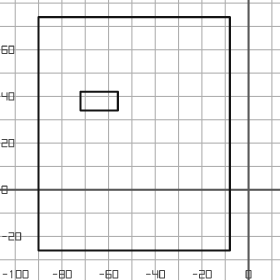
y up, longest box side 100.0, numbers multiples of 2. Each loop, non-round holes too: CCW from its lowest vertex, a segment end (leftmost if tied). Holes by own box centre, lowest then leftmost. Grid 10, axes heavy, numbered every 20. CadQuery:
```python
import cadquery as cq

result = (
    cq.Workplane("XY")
    .moveTo(-90.0, -26.0)
    .lineTo(-8.0, -26.0)
    .lineTo(-8.0, 74.0)
    .lineTo(-90.0, 74.0)
    .close()
    .moveTo(-72.0, 34.0)
    .lineTo(-56.0, 34.0)
    .lineTo(-56.0, 42.0)
    .lineTo(-72.0, 42.0)
    .close()
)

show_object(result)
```